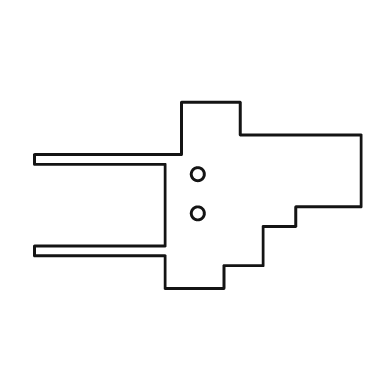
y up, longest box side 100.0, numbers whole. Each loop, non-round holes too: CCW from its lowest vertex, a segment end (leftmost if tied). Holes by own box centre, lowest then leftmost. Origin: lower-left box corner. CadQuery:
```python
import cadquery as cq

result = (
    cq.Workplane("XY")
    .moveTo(40.0, 0.0)
    .lineTo(58.0, 0.0)
    .lineTo(58.0, 7.0)
    .lineTo(70.0, 7.0)
    .lineTo(70.0, 19.0)
    .lineTo(80.0, 19.0)
    .lineTo(80.0, 25.0)
    .lineTo(100.0, 25.0)
    .lineTo(100.0, 47.0)
    .lineTo(63.0, 47.0)
    .lineTo(63.0, 57.0)
    .lineTo(45.0, 57.0)
    .lineTo(45.0, 41.0)
    .lineTo(0.0, 41.0)
    .lineTo(0.0, 38.0)
    .lineTo(40.0, 38.0)
    .lineTo(40.0, 13.0)
    .lineTo(0.0, 13.0)
    .lineTo(0.0, 10.0)
    .lineTo(40.0, 10.0)
    .close()
    .moveTo(50.0, 23.0)
    .circle(2.0)
    .moveTo(50.0, 35.0)
    .circle(2.0)
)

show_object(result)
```